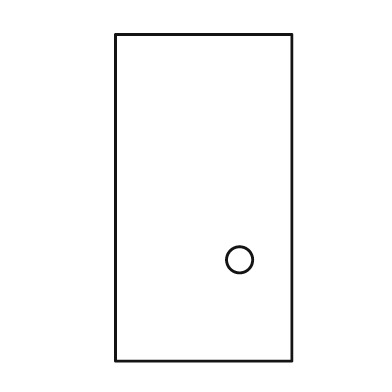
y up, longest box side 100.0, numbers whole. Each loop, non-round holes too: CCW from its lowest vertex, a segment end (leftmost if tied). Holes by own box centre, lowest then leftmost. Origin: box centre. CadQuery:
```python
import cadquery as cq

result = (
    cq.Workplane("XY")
    .moveTo(-27.0, -50.0)
    .lineTo(27.0, -50.0)
    .lineTo(27.0, 50.0)
    .lineTo(-27.0, 50.0)
    .close()
    .moveTo(11.0, -19.0)
    .circle(4.0)
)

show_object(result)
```